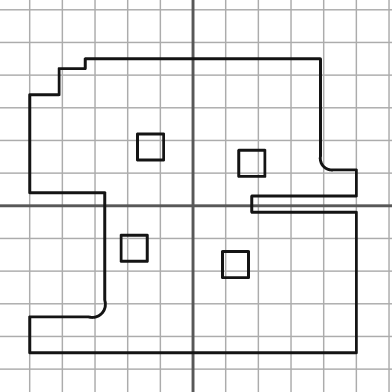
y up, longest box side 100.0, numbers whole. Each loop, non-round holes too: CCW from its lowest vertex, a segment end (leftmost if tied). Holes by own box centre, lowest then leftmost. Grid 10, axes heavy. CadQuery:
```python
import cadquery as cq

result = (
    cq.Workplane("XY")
    .moveTo(-50.0, -45.0)
    .lineTo(50.0, -45.0)
    .lineTo(50.0, -2.0)
    .lineTo(18.0, -2.0)
    .lineTo(18.0, 3.0)
    .lineTo(50.0, 3.0)
    .lineTo(50.0, 11.0)
    .lineTo(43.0, 11.0)
    .threePointArc((40.0, 12.0), (39.0, 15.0))
    .lineTo(39.0, 45.0)
    .lineTo(-33.0, 45.0)
    .lineTo(-33.0, 42.0)
    .lineTo(-41.0, 42.0)
    .lineTo(-41.0, 34.0)
    .lineTo(-50.0, 34.0)
    .lineTo(-50.0, 4.0)
    .lineTo(-27.0, 4.0)
    .lineTo(-27.0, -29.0)
    .threePointArc((-28.0, -33.0), (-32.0, -34.0))
    .lineTo(-50.0, -34.0)
    .close()
    .moveTo(9.0, -22.0)
    .lineTo(17.0, -22.0)
    .lineTo(17.0, -14.0)
    .lineTo(9.0, -14.0)
    .close()
    .moveTo(-22.0, -17.0)
    .lineTo(-14.0, -17.0)
    .lineTo(-14.0, -9.0)
    .lineTo(-22.0, -9.0)
    .close()
    .moveTo(14.0, 9.0)
    .lineTo(22.0, 9.0)
    .lineTo(22.0, 17.0)
    .lineTo(14.0, 17.0)
    .close()
    .moveTo(-17.0, 14.0)
    .lineTo(-9.0, 14.0)
    .lineTo(-9.0, 22.0)
    .lineTo(-17.0, 22.0)
    .close()
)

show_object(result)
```